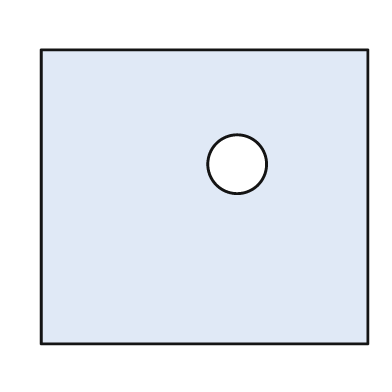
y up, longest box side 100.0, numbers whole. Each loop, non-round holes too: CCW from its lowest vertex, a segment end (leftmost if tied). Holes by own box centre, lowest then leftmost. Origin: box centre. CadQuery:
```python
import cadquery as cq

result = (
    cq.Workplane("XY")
    .moveTo(-50.0, -45.0)
    .lineTo(50.0, -45.0)
    .lineTo(50.0, 45.0)
    .lineTo(-50.0, 45.0)
    .close()
    .moveTo(10.0, 10.0)
    .circle(9.0)
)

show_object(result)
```